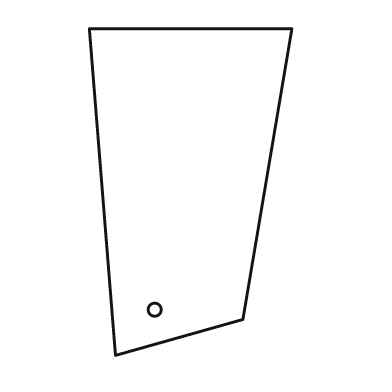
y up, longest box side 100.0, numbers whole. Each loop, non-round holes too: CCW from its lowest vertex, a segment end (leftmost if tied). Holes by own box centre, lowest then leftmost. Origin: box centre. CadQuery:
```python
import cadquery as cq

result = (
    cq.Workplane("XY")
    .moveTo(-23.0, -50.0)
    .lineTo(16.0, -39.0)
    .lineTo(31.0, 50.0)
    .lineTo(-31.0, 50.0)
    .close()
    .moveTo(-11.0, -36.0)
    .circle(2.0)
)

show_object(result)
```